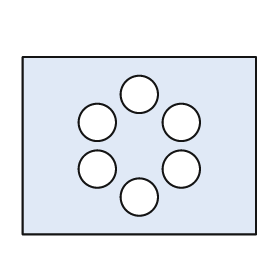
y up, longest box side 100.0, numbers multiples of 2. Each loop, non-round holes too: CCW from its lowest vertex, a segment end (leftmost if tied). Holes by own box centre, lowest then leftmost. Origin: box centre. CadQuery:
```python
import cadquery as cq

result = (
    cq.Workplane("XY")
    .moveTo(-50.0, -38.0)
    .lineTo(50.0, -38.0)
    .lineTo(50.0, 38.0)
    .lineTo(-50.0, 38.0)
    .close()
    .moveTo(0.0, -22.0)
    .circle(8.0)
    .moveTo(-18.0, -10.0)
    .circle(8.0)
    .moveTo(18.0, -10.0)
    .circle(8.0)
    .moveTo(-18.0, 10.0)
    .circle(8.0)
    .moveTo(18.0, 10.0)
    .circle(8.0)
    .moveTo(0.0, 22.0)
    .circle(8.0)
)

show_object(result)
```